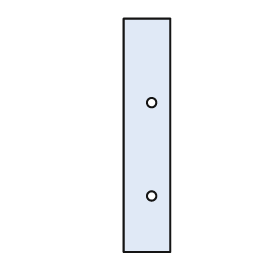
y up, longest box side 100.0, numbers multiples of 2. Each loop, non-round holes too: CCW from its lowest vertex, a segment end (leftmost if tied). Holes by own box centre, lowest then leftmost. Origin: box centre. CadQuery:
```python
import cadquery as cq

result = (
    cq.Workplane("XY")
    .moveTo(-10.0, -50.0)
    .lineTo(10.0, -50.0)
    .lineTo(10.0, 50.0)
    .lineTo(-10.0, 50.0)
    .close()
    .moveTo(2.0, -26.0)
    .circle(2.0)
    .moveTo(2.0, 14.0)
    .circle(2.0)
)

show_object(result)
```